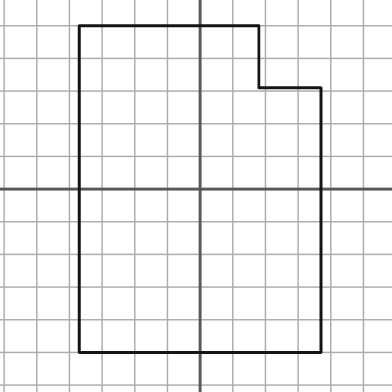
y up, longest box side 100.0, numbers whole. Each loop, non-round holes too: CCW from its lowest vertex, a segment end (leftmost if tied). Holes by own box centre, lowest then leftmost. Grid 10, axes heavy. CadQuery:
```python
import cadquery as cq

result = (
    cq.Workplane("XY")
    .moveTo(-37.0, -50.0)
    .lineTo(37.0, -50.0)
    .lineTo(37.0, 31.0)
    .lineTo(18.0, 31.0)
    .lineTo(18.0, 50.0)
    .lineTo(-37.0, 50.0)
    .close()
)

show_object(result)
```